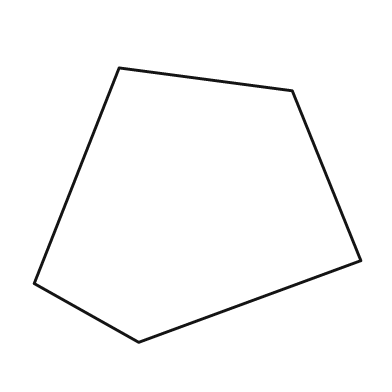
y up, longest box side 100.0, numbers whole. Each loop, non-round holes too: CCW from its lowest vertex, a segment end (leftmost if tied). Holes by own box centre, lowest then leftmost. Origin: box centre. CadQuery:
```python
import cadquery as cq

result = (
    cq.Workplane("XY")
    .moveTo(-18.0, -42.0)
    .lineTo(50.0, -17.0)
    .lineTo(29.0, 35.0)
    .lineTo(-24.0, 42.0)
    .lineTo(-50.0, -24.0)
    .close()
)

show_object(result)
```